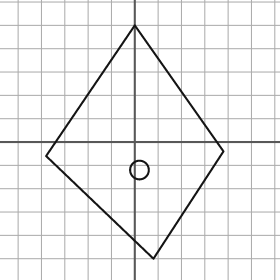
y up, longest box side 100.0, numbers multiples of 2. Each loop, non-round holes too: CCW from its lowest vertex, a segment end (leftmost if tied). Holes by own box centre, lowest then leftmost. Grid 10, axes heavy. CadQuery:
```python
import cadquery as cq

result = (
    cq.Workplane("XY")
    .moveTo(8.0, -50.0)
    .lineTo(38.0, -4.0)
    .lineTo(0.0, 50.0)
    .lineTo(-38.0, -6.0)
    .close()
    .moveTo(2.0, -12.0)
    .circle(4.0)
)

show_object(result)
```